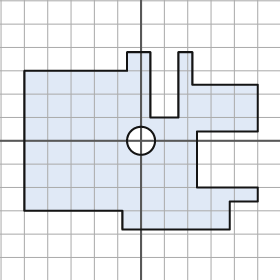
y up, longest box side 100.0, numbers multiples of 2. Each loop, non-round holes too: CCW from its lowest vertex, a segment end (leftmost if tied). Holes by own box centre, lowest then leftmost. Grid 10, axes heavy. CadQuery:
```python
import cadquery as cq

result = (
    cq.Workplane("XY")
    .moveTo(-8.0, -38.0)
    .lineTo(38.0, -38.0)
    .lineTo(38.0, -26.0)
    .lineTo(50.0, -26.0)
    .lineTo(50.0, -20.0)
    .lineTo(24.0, -20.0)
    .lineTo(24.0, 4.0)
    .lineTo(50.0, 4.0)
    .lineTo(50.0, 24.0)
    .lineTo(22.0, 24.0)
    .lineTo(22.0, 38.0)
    .lineTo(16.0, 38.0)
    .lineTo(16.0, 10.0)
    .lineTo(4.0, 10.0)
    .lineTo(4.0, 38.0)
    .lineTo(-6.0, 38.0)
    .lineTo(-6.0, 30.0)
    .lineTo(-50.0, 30.0)
    .lineTo(-50.0, -30.0)
    .lineTo(-8.0, -30.0)
    .close()
    .moveTo(0.0, 0.0)
    .circle(6.0)
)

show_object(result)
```